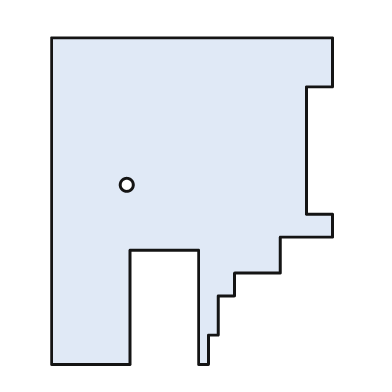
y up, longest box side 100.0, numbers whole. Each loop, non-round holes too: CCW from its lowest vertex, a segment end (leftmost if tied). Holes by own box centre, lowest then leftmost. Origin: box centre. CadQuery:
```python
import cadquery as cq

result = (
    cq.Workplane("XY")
    .moveTo(-43.0, -50.0)
    .lineTo(-19.0, -50.0)
    .lineTo(-19.0, -15.0)
    .lineTo(2.0, -15.0)
    .lineTo(2.0, -50.0)
    .lineTo(5.0, -50.0)
    .lineTo(5.0, -41.0)
    .lineTo(8.0, -41.0)
    .lineTo(8.0, -29.0)
    .lineTo(13.0, -29.0)
    .lineTo(13.0, -22.0)
    .lineTo(27.0, -22.0)
    .lineTo(27.0, -11.0)
    .lineTo(43.0, -11.0)
    .lineTo(43.0, -4.0)
    .lineTo(35.0, -4.0)
    .lineTo(35.0, 35.0)
    .lineTo(43.0, 35.0)
    .lineTo(43.0, 50.0)
    .lineTo(-43.0, 50.0)
    .close()
    .moveTo(-20.0, 5.0)
    .circle(2.0)
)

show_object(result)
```